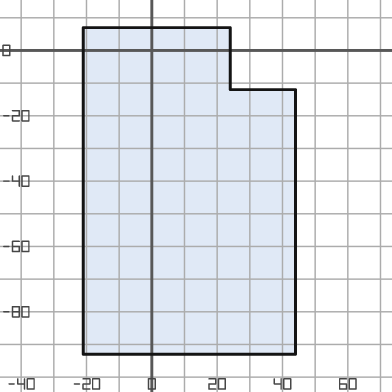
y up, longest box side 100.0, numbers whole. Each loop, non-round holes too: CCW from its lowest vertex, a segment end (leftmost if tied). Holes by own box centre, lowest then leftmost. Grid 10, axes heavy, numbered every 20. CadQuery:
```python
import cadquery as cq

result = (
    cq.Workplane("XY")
    .moveTo(-21.0, -93.0)
    .lineTo(44.0, -93.0)
    .lineTo(44.0, -12.0)
    .lineTo(24.0, -12.0)
    .lineTo(24.0, 7.0)
    .lineTo(-21.0, 7.0)
    .close()
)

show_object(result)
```